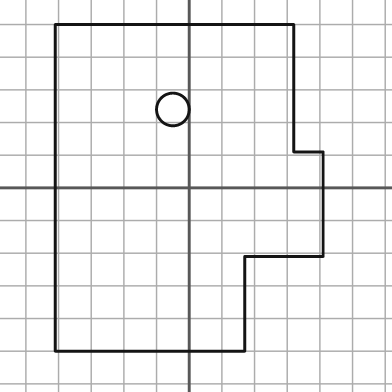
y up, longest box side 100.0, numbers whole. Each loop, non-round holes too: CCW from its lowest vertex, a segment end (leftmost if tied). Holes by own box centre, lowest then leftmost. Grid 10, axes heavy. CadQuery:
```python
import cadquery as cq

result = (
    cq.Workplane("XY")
    .moveTo(-41.0, -50.0)
    .lineTo(17.0, -50.0)
    .lineTo(17.0, -21.0)
    .lineTo(41.0, -21.0)
    .lineTo(41.0, 11.0)
    .lineTo(32.0, 11.0)
    .lineTo(32.0, 50.0)
    .lineTo(-41.0, 50.0)
    .close()
    .moveTo(-5.0, 24.0)
    .circle(5.0)
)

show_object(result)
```